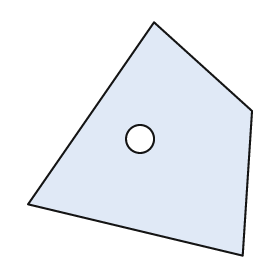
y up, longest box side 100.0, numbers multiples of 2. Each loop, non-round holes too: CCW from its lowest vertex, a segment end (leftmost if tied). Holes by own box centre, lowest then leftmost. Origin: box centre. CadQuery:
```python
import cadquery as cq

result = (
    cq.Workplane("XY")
    .moveTo(44.0, -50.0)
    .lineTo(48.0, 12.0)
    .lineTo(6.0, 50.0)
    .lineTo(-48.0, -28.0)
    .close()
    .moveTo(0.0, 0.0)
    .circle(6.0)
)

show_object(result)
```